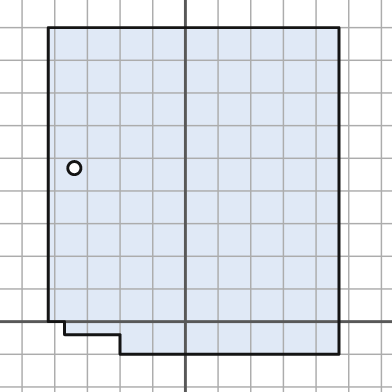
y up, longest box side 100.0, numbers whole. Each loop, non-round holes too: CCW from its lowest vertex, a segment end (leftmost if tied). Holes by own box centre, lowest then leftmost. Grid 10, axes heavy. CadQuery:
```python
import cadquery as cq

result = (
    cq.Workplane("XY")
    .moveTo(-20.0, -10.0)
    .lineTo(47.0, -10.0)
    .lineTo(47.0, 90.0)
    .lineTo(-42.0, 90.0)
    .lineTo(-42.0, 0.0)
    .lineTo(-37.0, 0.0)
    .lineTo(-37.0, -4.0)
    .lineTo(-20.0, -4.0)
    .close()
    .moveTo(-34.0, 47.0)
    .circle(2.0)
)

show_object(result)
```